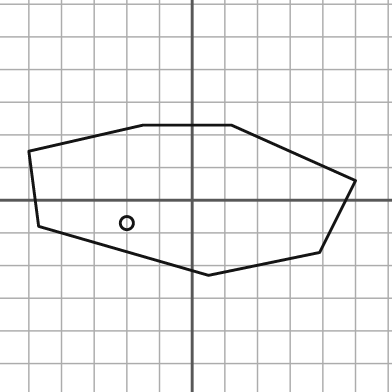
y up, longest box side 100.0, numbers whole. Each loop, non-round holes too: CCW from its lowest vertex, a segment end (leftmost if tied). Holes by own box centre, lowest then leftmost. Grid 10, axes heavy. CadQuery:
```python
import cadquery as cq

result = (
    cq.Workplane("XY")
    .moveTo(5.0, -23.0)
    .lineTo(39.0, -16.0)
    .lineTo(50.0, 6.0)
    .lineTo(12.0, 23.0)
    .lineTo(-15.0, 23.0)
    .lineTo(-50.0, 15.0)
    .lineTo(-47.0, -8.0)
    .close()
    .moveTo(-20.0, -7.0)
    .circle(2.0)
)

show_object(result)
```